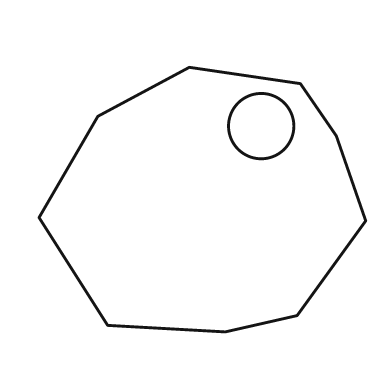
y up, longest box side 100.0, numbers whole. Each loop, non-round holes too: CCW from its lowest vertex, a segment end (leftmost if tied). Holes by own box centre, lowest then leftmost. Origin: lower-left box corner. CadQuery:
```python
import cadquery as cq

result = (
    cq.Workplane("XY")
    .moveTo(57.0, 0.0)
    .lineTo(79.0, 5.0)
    .lineTo(100.0, 34.0)
    .lineTo(91.0, 60.0)
    .lineTo(80.0, 76.0)
    .lineTo(46.0, 81.0)
    .lineTo(18.0, 66.0)
    .lineTo(0.0, 35.0)
    .lineTo(21.0, 2.0)
    .close()
    .moveTo(68.0, 63.0)
    .circle(10.0)
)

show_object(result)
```